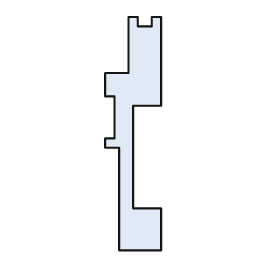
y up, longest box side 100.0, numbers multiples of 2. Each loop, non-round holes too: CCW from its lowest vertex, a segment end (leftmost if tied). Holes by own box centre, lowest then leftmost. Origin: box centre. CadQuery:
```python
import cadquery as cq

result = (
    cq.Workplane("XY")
    .moveTo(-6.0, -50.0)
    .lineTo(12.0, -50.0)
    .lineTo(12.0, -32.0)
    .lineTo(0.0, -32.0)
    .lineTo(0.0, 12.0)
    .lineTo(12.0, 12.0)
    .lineTo(12.0, 50.0)
    .lineTo(8.0, 50.0)
    .lineTo(8.0, 46.0)
    .lineTo(2.0, 46.0)
    .lineTo(2.0, 50.0)
    .lineTo(-2.0, 50.0)
    .lineTo(-2.0, 26.0)
    .lineTo(-12.0, 26.0)
    .lineTo(-12.0, 16.0)
    .lineTo(-8.0, 16.0)
    .lineTo(-8.0, -2.0)
    .lineTo(-12.0, -2.0)
    .lineTo(-12.0, -6.0)
    .lineTo(-6.0, -6.0)
    .close()
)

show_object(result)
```